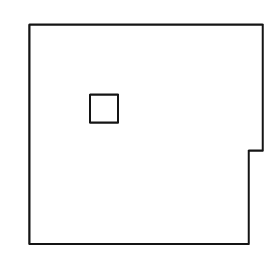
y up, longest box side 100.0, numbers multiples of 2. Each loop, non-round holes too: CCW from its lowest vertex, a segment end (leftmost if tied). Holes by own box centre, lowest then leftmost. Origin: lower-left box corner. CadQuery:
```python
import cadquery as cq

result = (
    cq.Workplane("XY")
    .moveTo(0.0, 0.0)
    .lineTo(94.0, 0.0)
    .lineTo(94.0, 40.0)
    .lineTo(100.0, 40.0)
    .lineTo(100.0, 94.0)
    .lineTo(0.0, 94.0)
    .close()
    .moveTo(26.0, 52.0)
    .lineTo(38.0, 52.0)
    .lineTo(38.0, 64.0)
    .lineTo(26.0, 64.0)
    .close()
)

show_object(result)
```